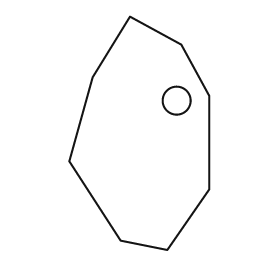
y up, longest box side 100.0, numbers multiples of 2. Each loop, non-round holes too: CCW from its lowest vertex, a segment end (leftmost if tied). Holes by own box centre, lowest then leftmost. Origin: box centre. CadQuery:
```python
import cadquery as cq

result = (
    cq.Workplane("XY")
    .moveTo(12.0, -50.0)
    .lineTo(30.0, -24.0)
    .lineTo(30.0, 16.0)
    .lineTo(18.0, 38.0)
    .lineTo(-4.0, 50.0)
    .lineTo(-20.0, 24.0)
    .lineTo(-30.0, -12.0)
    .lineTo(-8.0, -46.0)
    .close()
    .moveTo(16.0, 14.0)
    .circle(6.0)
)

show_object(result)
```